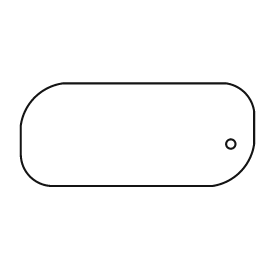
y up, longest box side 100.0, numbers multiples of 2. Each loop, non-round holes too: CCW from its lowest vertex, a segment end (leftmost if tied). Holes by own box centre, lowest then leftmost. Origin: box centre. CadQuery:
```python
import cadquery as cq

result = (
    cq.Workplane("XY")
    .moveTo(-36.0, -22.0)
    .lineTo(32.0, -22.0)
    .threePointArc((44.0, -16.0), (50.0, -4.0))
    .lineTo(50.0, 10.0)
    .threePointArc((46.0, 18.0), (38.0, 22.0))
    .lineTo(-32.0, 22.0)
    .threePointArc((-44.0, 16.0), (-50.0, 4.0))
    .lineTo(-50.0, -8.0)
    .threePointArc((-46.0, -18.0), (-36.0, -22.0))
    .close()
    .moveTo(40.0, -4.0)
    .circle(2.0)
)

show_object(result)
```